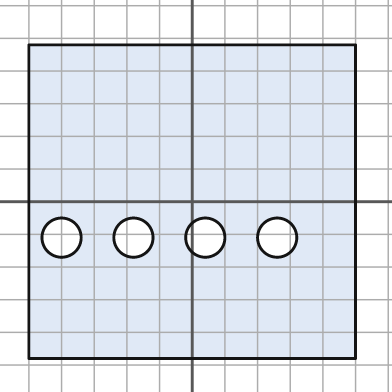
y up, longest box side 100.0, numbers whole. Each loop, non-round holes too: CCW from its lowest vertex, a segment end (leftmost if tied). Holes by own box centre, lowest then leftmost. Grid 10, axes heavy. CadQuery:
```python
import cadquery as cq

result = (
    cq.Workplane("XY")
    .moveTo(-50.0, -48.0)
    .lineTo(50.0, -48.0)
    .lineTo(50.0, 48.0)
    .lineTo(-50.0, 48.0)
    .close()
    .moveTo(-40.0, -11.0)
    .circle(6.0)
    .moveTo(-18.0, -11.0)
    .circle(6.0)
    .moveTo(4.0, -11.0)
    .circle(6.0)
    .moveTo(26.0, -11.0)
    .circle(6.0)
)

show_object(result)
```